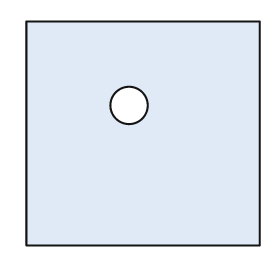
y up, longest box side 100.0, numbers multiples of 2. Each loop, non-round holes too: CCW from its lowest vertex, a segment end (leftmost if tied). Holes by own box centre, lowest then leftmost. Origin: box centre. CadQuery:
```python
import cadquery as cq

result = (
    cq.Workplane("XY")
    .moveTo(-50.0, -48.0)
    .lineTo(50.0, -48.0)
    .lineTo(50.0, 48.0)
    .lineTo(-50.0, 48.0)
    .close()
    .moveTo(-6.0, 12.0)
    .circle(8.0)
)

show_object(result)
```